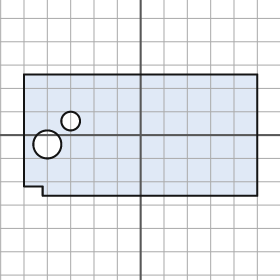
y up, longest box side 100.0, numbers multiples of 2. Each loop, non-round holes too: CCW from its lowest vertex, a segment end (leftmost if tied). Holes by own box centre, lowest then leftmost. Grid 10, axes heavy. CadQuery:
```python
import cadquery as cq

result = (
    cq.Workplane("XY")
    .moveTo(-42.0, -26.0)
    .lineTo(50.0, -26.0)
    .lineTo(50.0, 26.0)
    .lineTo(-50.0, 26.0)
    .lineTo(-50.0, -22.0)
    .lineTo(-42.0, -22.0)
    .close()
    .moveTo(-40.0, -4.0)
    .circle(6.0)
    .moveTo(-30.0, 6.0)
    .circle(4.0)
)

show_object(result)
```